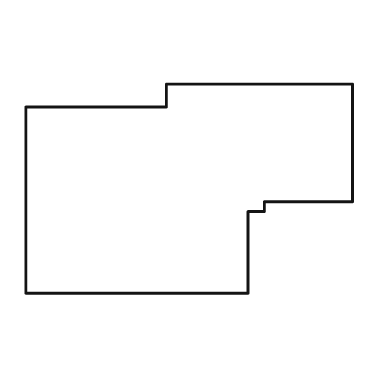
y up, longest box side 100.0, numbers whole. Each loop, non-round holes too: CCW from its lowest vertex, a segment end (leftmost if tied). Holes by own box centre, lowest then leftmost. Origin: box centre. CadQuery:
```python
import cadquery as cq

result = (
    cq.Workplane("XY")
    .moveTo(-50.0, -32.0)
    .lineTo(18.0, -32.0)
    .lineTo(18.0, -7.0)
    .lineTo(23.0, -7.0)
    .lineTo(23.0, -4.0)
    .lineTo(50.0, -4.0)
    .lineTo(50.0, 32.0)
    .lineTo(-7.0, 32.0)
    .lineTo(-7.0, 25.0)
    .lineTo(-50.0, 25.0)
    .close()
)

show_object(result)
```